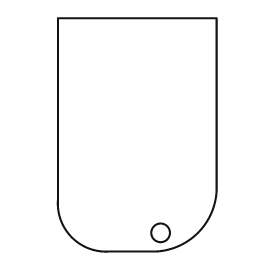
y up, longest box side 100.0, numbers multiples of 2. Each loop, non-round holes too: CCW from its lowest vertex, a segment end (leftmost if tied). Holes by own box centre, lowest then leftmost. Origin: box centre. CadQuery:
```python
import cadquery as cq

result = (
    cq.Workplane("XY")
    .moveTo(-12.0, -50.0)
    .lineTo(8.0, -50.0)
    .threePointArc((26.0, -42.0), (34.0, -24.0))
    .lineTo(34.0, 50.0)
    .lineTo(-34.0, 50.0)
    .lineTo(-34.0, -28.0)
    .threePointArc((-28.0, -44.0), (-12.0, -50.0))
    .close()
    .moveTo(10.0, -42.0)
    .circle(4.0)
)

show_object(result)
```